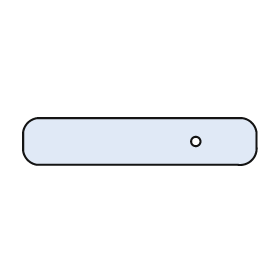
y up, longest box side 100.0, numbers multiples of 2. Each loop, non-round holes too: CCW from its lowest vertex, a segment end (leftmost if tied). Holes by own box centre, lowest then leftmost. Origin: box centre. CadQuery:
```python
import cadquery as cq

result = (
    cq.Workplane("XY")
    .moveTo(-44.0, -10.0)
    .lineTo(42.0, -10.0)
    .threePointArc((48.0, -8.0), (50.0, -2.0))
    .lineTo(50.0, 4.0)
    .threePointArc((48.0, 8.0), (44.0, 10.0))
    .lineTo(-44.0, 10.0)
    .threePointArc((-48.0, 8.0), (-50.0, 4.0))
    .lineTo(-50.0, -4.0)
    .threePointArc((-48.0, -8.0), (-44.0, -10.0))
    .close()
    .moveTo(24.0, 0.0)
    .circle(2.0)
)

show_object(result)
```